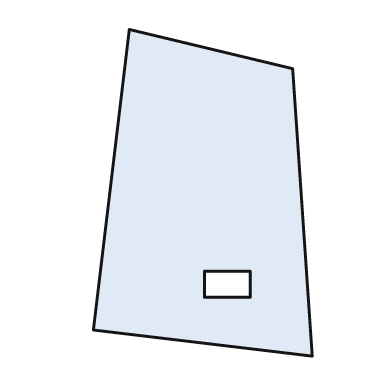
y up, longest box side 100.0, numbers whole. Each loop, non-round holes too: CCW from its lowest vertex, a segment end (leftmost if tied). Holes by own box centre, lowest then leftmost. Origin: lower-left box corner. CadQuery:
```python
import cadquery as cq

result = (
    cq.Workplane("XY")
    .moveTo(67.0, 0.0)
    .lineTo(61.0, 88.0)
    .lineTo(11.0, 100.0)
    .lineTo(0.0, 8.0)
    .close()
    .moveTo(34.0, 18.0)
    .lineTo(48.0, 18.0)
    .lineTo(48.0, 26.0)
    .lineTo(34.0, 26.0)
    .close()
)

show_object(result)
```